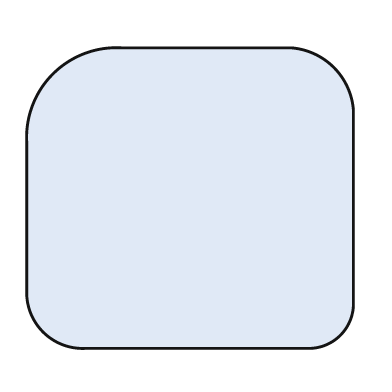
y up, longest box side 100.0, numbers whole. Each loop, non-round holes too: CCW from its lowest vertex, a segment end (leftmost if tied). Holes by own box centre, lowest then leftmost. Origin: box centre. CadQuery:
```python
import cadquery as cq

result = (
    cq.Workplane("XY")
    .moveTo(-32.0, -46.0)
    .lineTo(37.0, -46.0)
    .threePointArc((46.0, -42.0), (50.0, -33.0))
    .lineTo(50.0, 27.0)
    .threePointArc((44.0, 40.0), (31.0, 46.0))
    .lineTo(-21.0, 46.0)
    .threePointArc((-42.0, 38.0), (-50.0, 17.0))
    .lineTo(-50.0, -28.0)
    .threePointArc((-45.0, -41.0), (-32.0, -46.0))
    .close()
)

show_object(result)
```